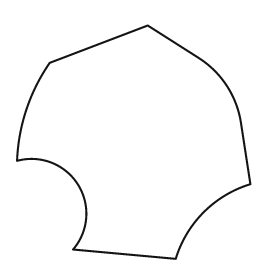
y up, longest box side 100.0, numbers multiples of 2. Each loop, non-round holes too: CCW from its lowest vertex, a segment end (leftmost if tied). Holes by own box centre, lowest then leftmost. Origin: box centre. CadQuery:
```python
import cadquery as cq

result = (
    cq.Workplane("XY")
    .moveTo(18.0, -50.0)
    .threePointArc((30.0, -30.0), (50.0, -18.0))
    .lineTo(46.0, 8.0)
    .threePointArc((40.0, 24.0), (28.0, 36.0))
    .lineTo(6.0, 50.0)
    .lineTo(-36.0, 34.0)
    .threePointArc((-46.0, 14.0), (-50.0, -8.0))
    .threePointArc((-24.0, -18.0), (-26.0, -46.0))
    .close()
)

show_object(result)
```